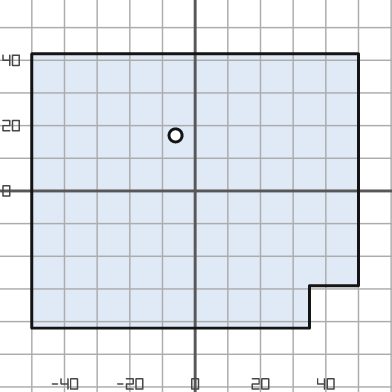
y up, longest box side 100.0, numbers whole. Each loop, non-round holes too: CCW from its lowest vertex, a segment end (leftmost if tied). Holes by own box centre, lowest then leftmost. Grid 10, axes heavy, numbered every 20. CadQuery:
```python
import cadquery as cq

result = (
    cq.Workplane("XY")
    .moveTo(-50.0, -42.0)
    .lineTo(35.0, -42.0)
    .lineTo(35.0, -29.0)
    .lineTo(50.0, -29.0)
    .lineTo(50.0, 42.0)
    .lineTo(-50.0, 42.0)
    .close()
    .moveTo(-6.0, 17.0)
    .circle(2.0)
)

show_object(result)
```